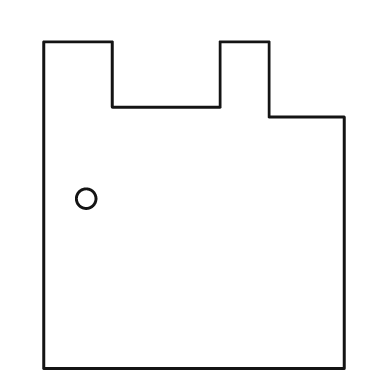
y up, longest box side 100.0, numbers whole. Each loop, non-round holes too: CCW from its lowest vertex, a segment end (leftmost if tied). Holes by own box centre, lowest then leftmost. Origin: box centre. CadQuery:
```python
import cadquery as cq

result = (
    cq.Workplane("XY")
    .moveTo(-46.0, -50.0)
    .lineTo(46.0, -50.0)
    .lineTo(46.0, 27.0)
    .lineTo(23.0, 27.0)
    .lineTo(23.0, 50.0)
    .lineTo(8.0, 50.0)
    .lineTo(8.0, 30.0)
    .lineTo(-25.0, 30.0)
    .lineTo(-25.0, 50.0)
    .lineTo(-46.0, 50.0)
    .close()
    .moveTo(-33.0, 2.0)
    .circle(3.0)
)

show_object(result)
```